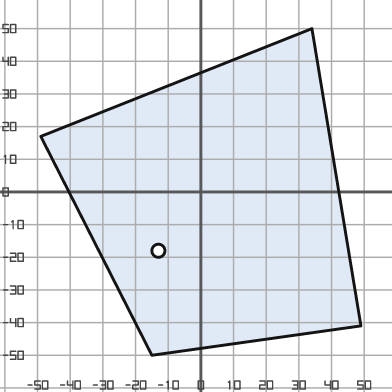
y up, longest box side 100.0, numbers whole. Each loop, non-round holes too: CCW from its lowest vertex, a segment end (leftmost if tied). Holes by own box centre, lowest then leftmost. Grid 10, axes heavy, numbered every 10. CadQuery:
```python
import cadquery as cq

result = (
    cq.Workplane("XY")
    .moveTo(-15.0, -50.0)
    .lineTo(49.0, -41.0)
    .lineTo(34.0, 50.0)
    .lineTo(-49.0, 17.0)
    .close()
    .moveTo(-13.0, -18.0)
    .circle(2.0)
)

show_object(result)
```